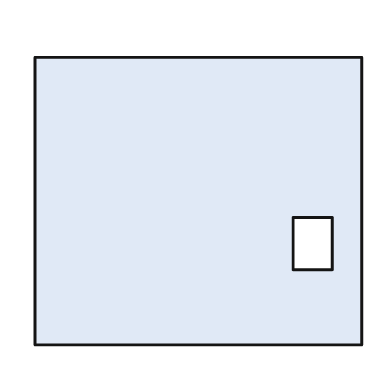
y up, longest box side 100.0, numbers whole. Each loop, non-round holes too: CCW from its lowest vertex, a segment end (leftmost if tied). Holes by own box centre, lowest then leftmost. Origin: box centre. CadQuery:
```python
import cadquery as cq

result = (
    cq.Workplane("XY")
    .moveTo(-50.0, -44.0)
    .lineTo(50.0, -44.0)
    .lineTo(50.0, 44.0)
    .lineTo(-50.0, 44.0)
    .close()
    .moveTo(29.0, -21.0)
    .lineTo(41.0, -21.0)
    .lineTo(41.0, -5.0)
    .lineTo(29.0, -5.0)
    .close()
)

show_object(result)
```